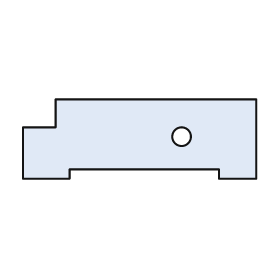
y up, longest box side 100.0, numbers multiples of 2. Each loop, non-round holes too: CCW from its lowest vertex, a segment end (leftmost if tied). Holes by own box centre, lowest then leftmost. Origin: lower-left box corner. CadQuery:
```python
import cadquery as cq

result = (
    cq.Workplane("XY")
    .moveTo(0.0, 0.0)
    .lineTo(20.0, 0.0)
    .lineTo(20.0, 4.0)
    .lineTo(84.0, 4.0)
    .lineTo(84.0, 0.0)
    .lineTo(100.0, 0.0)
    .lineTo(100.0, 34.0)
    .lineTo(14.0, 34.0)
    .lineTo(14.0, 22.0)
    .lineTo(0.0, 22.0)
    .close()
    .moveTo(68.0, 18.0)
    .circle(4.0)
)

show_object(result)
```